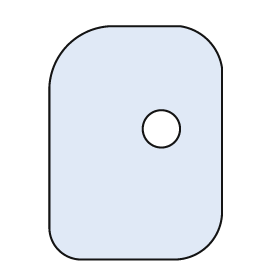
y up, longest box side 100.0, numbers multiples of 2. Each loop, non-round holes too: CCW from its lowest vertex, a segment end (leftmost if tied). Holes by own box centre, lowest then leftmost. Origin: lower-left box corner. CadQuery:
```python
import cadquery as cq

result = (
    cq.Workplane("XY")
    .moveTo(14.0, 0.0)
    .lineTo(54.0, 0.0)
    .threePointArc((68.0, 6.0), (74.0, 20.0))
    .lineTo(74.0, 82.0)
    .threePointArc((68.0, 94.0), (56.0, 100.0))
    .lineTo(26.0, 100.0)
    .threePointArc((8.0, 92.0), (0.0, 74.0))
    .lineTo(0.0, 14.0)
    .threePointArc((4.0, 4.0), (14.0, 0.0))
    .close()
    .moveTo(48.0, 56.0)
    .circle(8.0)
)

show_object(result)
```